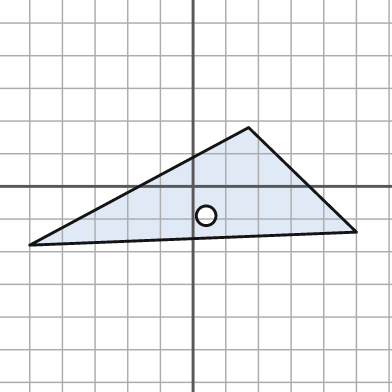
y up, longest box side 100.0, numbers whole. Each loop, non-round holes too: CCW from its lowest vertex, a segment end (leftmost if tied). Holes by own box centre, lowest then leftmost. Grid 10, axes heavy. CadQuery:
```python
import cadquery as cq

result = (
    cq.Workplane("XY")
    .moveTo(-50.0, -18.0)
    .lineTo(50.0, -14.0)
    .lineTo(17.0, 18.0)
    .close()
    .moveTo(4.0, -9.0)
    .circle(3.0)
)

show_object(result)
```